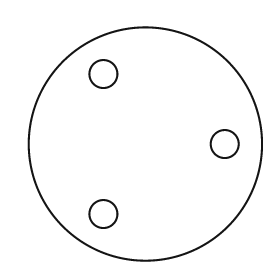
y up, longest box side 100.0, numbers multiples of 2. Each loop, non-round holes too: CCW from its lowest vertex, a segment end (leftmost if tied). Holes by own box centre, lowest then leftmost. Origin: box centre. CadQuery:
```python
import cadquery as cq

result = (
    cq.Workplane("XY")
    .moveTo(0.0, 0.0)
    .circle(50.0)
    .moveTo(-18.0, -30.0)
    .circle(6.0)
    .moveTo(34.0, 0.0)
    .circle(6.0)
    .moveTo(-18.0, 30.0)
    .circle(6.0)
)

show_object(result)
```